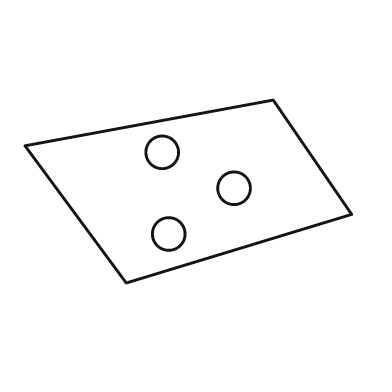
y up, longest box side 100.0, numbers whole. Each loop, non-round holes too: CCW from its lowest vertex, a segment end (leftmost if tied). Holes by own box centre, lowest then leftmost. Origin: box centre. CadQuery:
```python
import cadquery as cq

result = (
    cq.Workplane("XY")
    .moveTo(-19.0, -28.0)
    .lineTo(50.0, -7.0)
    .lineTo(26.0, 28.0)
    .lineTo(-50.0, 14.0)
    .close()
    .moveTo(-6.0, -13.0)
    .circle(5.0)
    .moveTo(14.0, 1.0)
    .circle(5.0)
    .moveTo(-8.0, 12.0)
    .circle(5.0)
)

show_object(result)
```